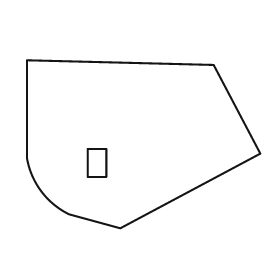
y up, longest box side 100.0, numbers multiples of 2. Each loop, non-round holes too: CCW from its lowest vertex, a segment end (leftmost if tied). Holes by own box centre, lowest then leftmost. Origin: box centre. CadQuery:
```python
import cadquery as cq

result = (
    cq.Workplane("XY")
    .moveTo(-10.0, -36.0)
    .lineTo(50.0, -4.0)
    .lineTo(30.0, 34.0)
    .lineTo(-50.0, 36.0)
    .lineTo(-50.0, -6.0)
    .threePointArc((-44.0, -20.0), (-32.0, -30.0))
    .close()
    .moveTo(-24.0, -14.0)
    .lineTo(-16.0, -14.0)
    .lineTo(-16.0, -2.0)
    .lineTo(-24.0, -2.0)
    .close()
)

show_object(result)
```